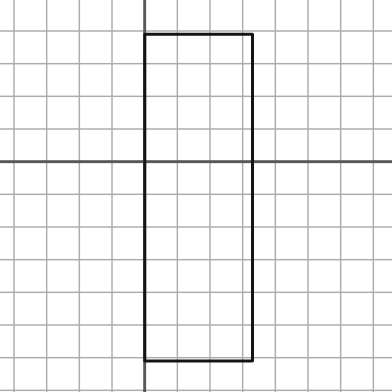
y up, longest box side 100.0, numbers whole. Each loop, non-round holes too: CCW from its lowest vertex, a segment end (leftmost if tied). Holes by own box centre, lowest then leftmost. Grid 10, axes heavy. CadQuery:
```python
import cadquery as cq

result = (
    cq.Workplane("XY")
    .moveTo(0.0, -61.0)
    .lineTo(33.0, -61.0)
    .lineTo(33.0, 39.0)
    .lineTo(0.0, 39.0)
    .close()
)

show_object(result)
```